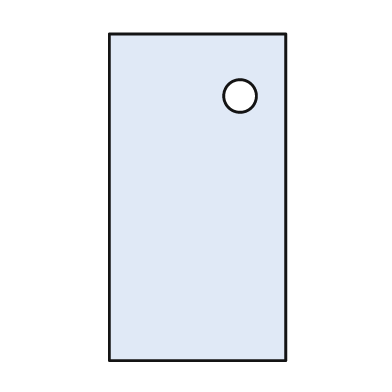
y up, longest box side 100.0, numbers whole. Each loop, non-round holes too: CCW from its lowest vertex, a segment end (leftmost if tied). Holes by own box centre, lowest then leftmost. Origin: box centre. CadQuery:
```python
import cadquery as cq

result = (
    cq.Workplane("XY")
    .moveTo(-27.0, -50.0)
    .lineTo(27.0, -50.0)
    .lineTo(27.0, 50.0)
    .lineTo(-27.0, 50.0)
    .close()
    .moveTo(13.0, 31.0)
    .circle(5.0)
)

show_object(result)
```